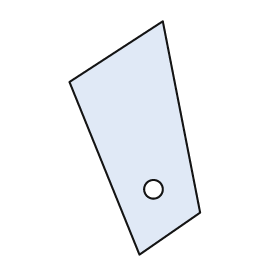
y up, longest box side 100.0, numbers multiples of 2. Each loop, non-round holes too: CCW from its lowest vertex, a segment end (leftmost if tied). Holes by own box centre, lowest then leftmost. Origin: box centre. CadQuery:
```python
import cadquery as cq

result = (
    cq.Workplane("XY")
    .moveTo(2.0, -50.0)
    .lineTo(28.0, -32.0)
    .lineTo(12.0, 50.0)
    .lineTo(-28.0, 24.0)
    .close()
    .moveTo(8.0, -22.0)
    .circle(4.0)
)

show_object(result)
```